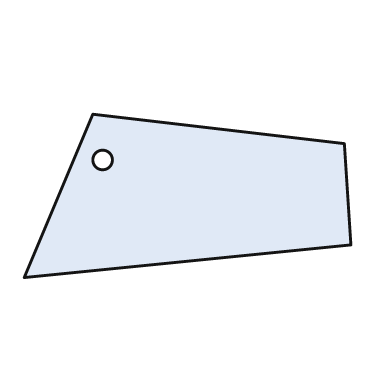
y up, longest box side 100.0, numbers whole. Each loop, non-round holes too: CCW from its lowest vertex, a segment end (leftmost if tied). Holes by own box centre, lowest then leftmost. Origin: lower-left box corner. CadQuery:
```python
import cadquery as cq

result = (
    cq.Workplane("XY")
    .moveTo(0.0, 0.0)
    .lineTo(100.0, 10.0)
    .lineTo(98.0, 41.0)
    .lineTo(21.0, 50.0)
    .close()
    .moveTo(24.0, 36.0)
    .circle(3.0)
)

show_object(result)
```